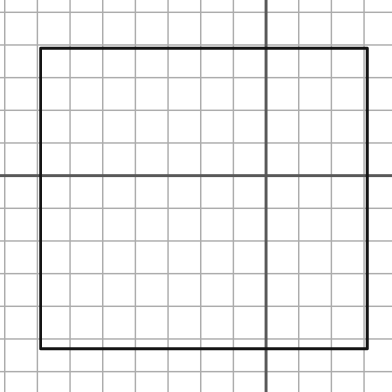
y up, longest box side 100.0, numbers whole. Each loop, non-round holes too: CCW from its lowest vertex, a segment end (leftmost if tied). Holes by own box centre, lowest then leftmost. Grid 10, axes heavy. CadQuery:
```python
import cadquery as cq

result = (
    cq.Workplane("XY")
    .moveTo(-69.0, -53.0)
    .lineTo(31.0, -53.0)
    .lineTo(31.0, 39.0)
    .lineTo(-69.0, 39.0)
    .close()
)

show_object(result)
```